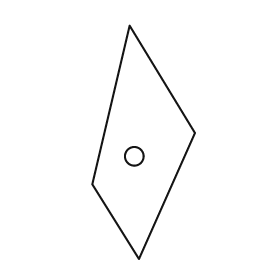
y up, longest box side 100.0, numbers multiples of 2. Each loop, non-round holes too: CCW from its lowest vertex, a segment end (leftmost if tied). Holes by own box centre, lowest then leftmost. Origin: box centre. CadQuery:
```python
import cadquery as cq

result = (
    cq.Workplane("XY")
    .moveTo(-2.0, -50.0)
    .lineTo(22.0, 4.0)
    .lineTo(-6.0, 50.0)
    .lineTo(-22.0, -18.0)
    .close()
    .moveTo(-4.0, -6.0)
    .circle(4.0)
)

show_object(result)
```